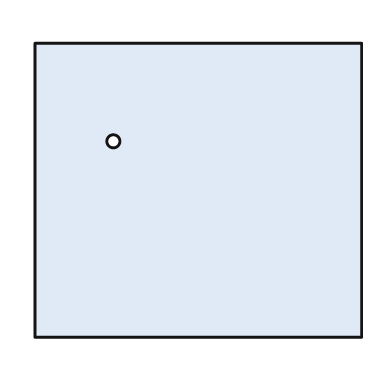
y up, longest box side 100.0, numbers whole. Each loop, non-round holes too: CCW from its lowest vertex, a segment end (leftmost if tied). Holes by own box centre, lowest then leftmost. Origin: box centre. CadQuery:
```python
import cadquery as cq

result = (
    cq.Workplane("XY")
    .moveTo(-50.0, -45.0)
    .lineTo(50.0, -45.0)
    .lineTo(50.0, 45.0)
    .lineTo(-50.0, 45.0)
    .close()
    .moveTo(-26.0, 15.0)
    .circle(2.0)
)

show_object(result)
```